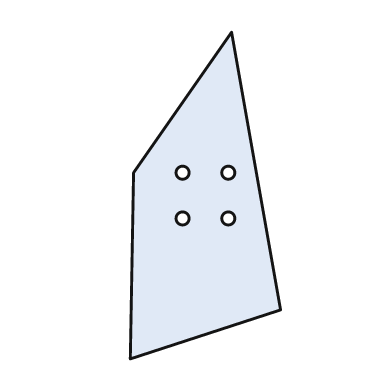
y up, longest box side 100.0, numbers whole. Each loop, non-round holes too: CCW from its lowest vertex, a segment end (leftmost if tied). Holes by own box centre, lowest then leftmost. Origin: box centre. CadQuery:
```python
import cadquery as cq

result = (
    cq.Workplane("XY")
    .moveTo(-23.0, -50.0)
    .lineTo(23.0, -35.0)
    .lineTo(8.0, 50.0)
    .lineTo(-22.0, 7.0)
    .close()
    .moveTo(-7.0, -7.0)
    .circle(2.0)
    .moveTo(7.0, -7.0)
    .circle(2.0)
    .moveTo(-7.0, 7.0)
    .circle(2.0)
    .moveTo(7.0, 7.0)
    .circle(2.0)
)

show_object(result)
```